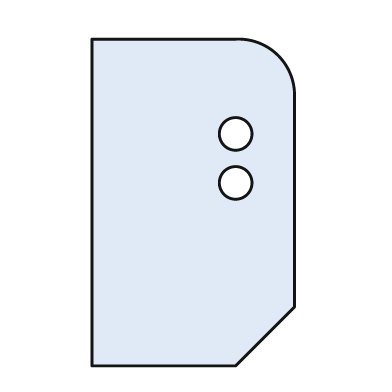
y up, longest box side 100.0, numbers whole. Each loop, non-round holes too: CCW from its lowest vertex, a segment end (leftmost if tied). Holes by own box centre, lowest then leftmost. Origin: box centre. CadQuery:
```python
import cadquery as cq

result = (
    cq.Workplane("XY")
    .moveTo(-31.0, -50.0)
    .lineTo(13.0, -50.0)
    .lineTo(31.0, -32.0)
    .lineTo(31.0, 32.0)
    .threePointArc((26.0, 45.0), (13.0, 50.0))
    .lineTo(-31.0, 50.0)
    .close()
    .moveTo(13.0, 6.0)
    .circle(5.0)
    .moveTo(13.0, 21.0)
    .circle(5.0)
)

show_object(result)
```